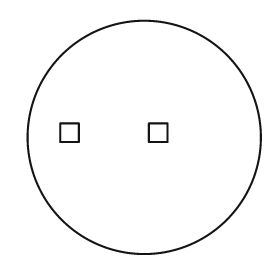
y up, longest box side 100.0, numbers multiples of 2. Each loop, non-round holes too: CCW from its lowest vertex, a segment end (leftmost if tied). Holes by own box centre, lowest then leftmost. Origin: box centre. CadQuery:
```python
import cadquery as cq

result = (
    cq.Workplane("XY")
    .moveTo(0.0, 0.0)
    .circle(50.0)
    .moveTo(-36.0, -2.0)
    .lineTo(-28.0, -2.0)
    .lineTo(-28.0, 6.0)
    .lineTo(-36.0, 6.0)
    .close()
    .moveTo(2.0, -2.0)
    .lineTo(10.0, -2.0)
    .lineTo(10.0, 6.0)
    .lineTo(2.0, 6.0)
    .close()
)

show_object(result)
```